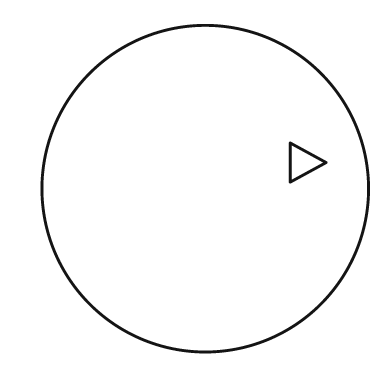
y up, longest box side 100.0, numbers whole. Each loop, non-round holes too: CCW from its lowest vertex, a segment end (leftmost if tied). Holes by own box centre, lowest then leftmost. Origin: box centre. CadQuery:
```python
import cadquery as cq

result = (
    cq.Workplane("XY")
    .moveTo(0.0, 0.0)
    .circle(50.0)
    .moveTo(26.0, 2.0)
    .lineTo(37.0, 8.0)
    .lineTo(26.0, 14.0)
    .close()
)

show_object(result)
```